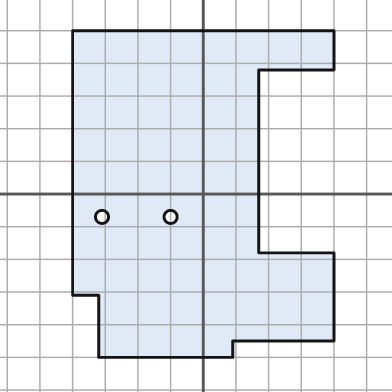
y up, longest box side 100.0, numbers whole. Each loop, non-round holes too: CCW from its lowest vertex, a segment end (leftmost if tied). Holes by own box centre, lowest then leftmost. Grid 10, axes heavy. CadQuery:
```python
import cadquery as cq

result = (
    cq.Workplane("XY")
    .moveTo(-32.0, -50.0)
    .lineTo(9.0, -50.0)
    .lineTo(9.0, -45.0)
    .lineTo(40.0, -45.0)
    .lineTo(40.0, -18.0)
    .lineTo(17.0, -18.0)
    .lineTo(17.0, 38.0)
    .lineTo(40.0, 38.0)
    .lineTo(40.0, 50.0)
    .lineTo(-40.0, 50.0)
    .lineTo(-40.0, -31.0)
    .lineTo(-32.0, -31.0)
    .close()
    .moveTo(-31.0, -7.0)
    .circle(2.0)
    .moveTo(-10.0, -7.0)
    .circle(2.0)
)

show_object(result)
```